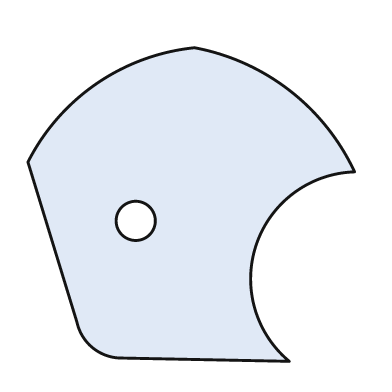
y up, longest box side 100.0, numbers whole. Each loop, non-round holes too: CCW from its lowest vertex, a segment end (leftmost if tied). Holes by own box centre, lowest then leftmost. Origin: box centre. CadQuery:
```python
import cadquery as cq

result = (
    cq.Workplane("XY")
    .moveTo(30.0, -48.0)
    .threePointArc((20.0, -12.0), (50.0, 10.0))
    .threePointArc((30.0, 35.0), (1.0, 48.0))
    .threePointArc((-29.0, 37.0), (-50.0, 13.0))
    .lineTo(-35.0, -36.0)
    .threePointArc((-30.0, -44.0), (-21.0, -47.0))
    .close()
    .moveTo(-17.0, -5.0)
    .circle(6.0)
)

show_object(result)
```